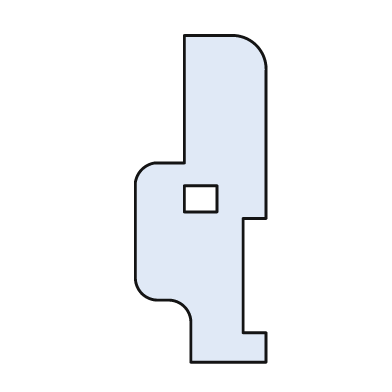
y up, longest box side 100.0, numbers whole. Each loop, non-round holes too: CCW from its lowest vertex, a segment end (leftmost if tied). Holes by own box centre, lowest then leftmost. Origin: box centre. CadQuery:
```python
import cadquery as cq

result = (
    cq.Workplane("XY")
    .moveTo(-3.0, -50.0)
    .lineTo(20.0, -50.0)
    .lineTo(20.0, -41.0)
    .lineTo(13.0, -41.0)
    .lineTo(13.0, -6.0)
    .lineTo(20.0, -6.0)
    .lineTo(20.0, 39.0)
    .threePointArc((17.0, 47.0), (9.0, 50.0))
    .lineTo(-5.0, 50.0)
    .lineTo(-5.0, 11.0)
    .lineTo(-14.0, 11.0)
    .threePointArc((-18.0, 9.0), (-20.0, 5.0))
    .lineTo(-20.0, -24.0)
    .threePointArc((-18.0, -29.0), (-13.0, -31.0))
    .lineTo(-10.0, -31.0)
    .threePointArc((-5.0, -33.0), (-3.0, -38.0))
    .close()
    .moveTo(-5.0, -4.0)
    .lineTo(5.0, -4.0)
    .lineTo(5.0, 4.0)
    .lineTo(-5.0, 4.0)
    .close()
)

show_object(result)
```